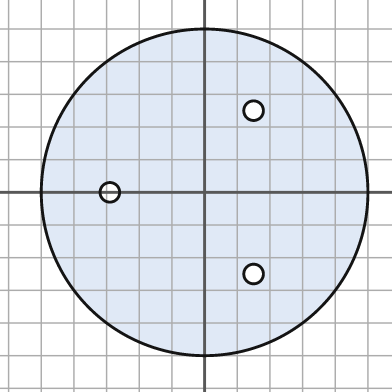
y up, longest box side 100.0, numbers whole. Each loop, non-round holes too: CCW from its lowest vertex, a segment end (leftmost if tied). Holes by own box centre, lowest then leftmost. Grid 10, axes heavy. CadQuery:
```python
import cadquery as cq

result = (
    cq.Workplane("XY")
    .moveTo(0.0, 0.0)
    .circle(50.0)
    .moveTo(15.0, -25.0)
    .circle(3.0)
    .moveTo(-29.0, 0.0)
    .circle(3.0)
    .moveTo(15.0, 25.0)
    .circle(3.0)
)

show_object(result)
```